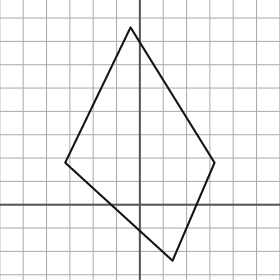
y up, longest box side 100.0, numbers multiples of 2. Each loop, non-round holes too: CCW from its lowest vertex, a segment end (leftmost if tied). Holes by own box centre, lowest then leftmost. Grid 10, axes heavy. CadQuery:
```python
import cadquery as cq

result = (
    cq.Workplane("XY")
    .moveTo(14.0, -24.0)
    .lineTo(32.0, 18.0)
    .lineTo(-4.0, 76.0)
    .lineTo(-32.0, 18.0)
    .close()
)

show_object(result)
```